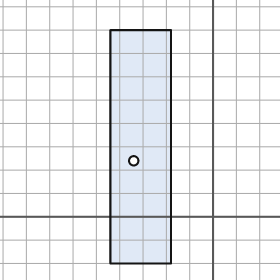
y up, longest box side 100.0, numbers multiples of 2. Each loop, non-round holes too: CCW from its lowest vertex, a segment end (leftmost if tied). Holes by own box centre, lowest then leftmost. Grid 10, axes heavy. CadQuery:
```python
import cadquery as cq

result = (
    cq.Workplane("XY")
    .moveTo(-44.0, -20.0)
    .lineTo(-18.0, -20.0)
    .lineTo(-18.0, 80.0)
    .lineTo(-44.0, 80.0)
    .close()
    .moveTo(-34.0, 24.0)
    .circle(2.0)
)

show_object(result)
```